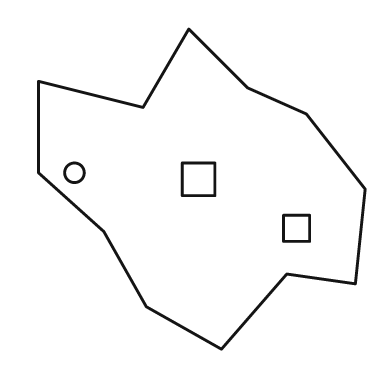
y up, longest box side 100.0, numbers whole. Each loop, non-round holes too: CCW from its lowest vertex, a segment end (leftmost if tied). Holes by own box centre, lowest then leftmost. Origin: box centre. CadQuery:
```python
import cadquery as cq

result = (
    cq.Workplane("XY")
    .moveTo(6.0, -49.0)
    .lineTo(26.0, -26.0)
    .lineTo(47.0, -29.0)
    .lineTo(50.0, 0.0)
    .lineTo(32.0, 23.0)
    .lineTo(14.0, 31.0)
    .lineTo(-4.0, 49.0)
    .lineTo(-18.0, 25.0)
    .lineTo(-50.0, 33.0)
    .lineTo(-50.0, 5.0)
    .lineTo(-30.0, -13.0)
    .lineTo(-17.0, -36.0)
    .close()
    .moveTo(25.0, -16.0)
    .lineTo(33.0, -16.0)
    .lineTo(33.0, -8.0)
    .lineTo(25.0, -8.0)
    .close()
    .moveTo(-6.0, -2.0)
    .lineTo(4.0, -2.0)
    .lineTo(4.0, 8.0)
    .lineTo(-6.0, 8.0)
    .close()
    .moveTo(-39.0, 5.0)
    .circle(3.0)
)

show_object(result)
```